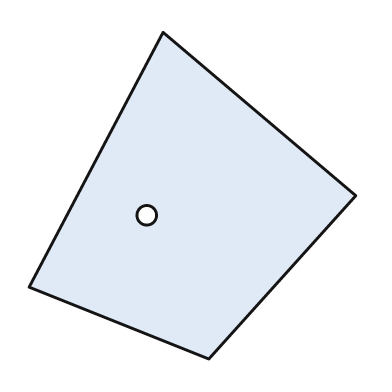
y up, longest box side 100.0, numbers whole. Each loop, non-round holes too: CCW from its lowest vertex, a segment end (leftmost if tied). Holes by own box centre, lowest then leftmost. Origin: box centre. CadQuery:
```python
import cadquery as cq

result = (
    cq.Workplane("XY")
    .moveTo(5.0, -50.0)
    .lineTo(50.0, 0.0)
    .lineTo(-9.0, 50.0)
    .lineTo(-50.0, -28.0)
    .close()
    .moveTo(-14.0, -6.0)
    .circle(3.0)
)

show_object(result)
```